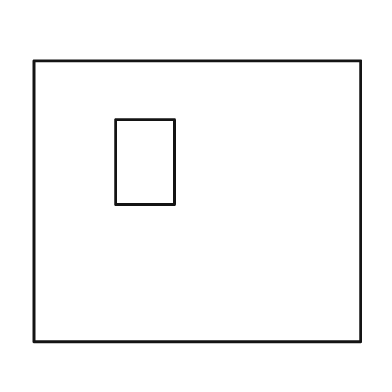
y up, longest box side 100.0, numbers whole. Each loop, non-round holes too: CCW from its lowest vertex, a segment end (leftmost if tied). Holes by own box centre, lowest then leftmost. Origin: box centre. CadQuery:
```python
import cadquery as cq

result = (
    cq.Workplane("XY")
    .moveTo(-50.0, -43.0)
    .lineTo(50.0, -43.0)
    .lineTo(50.0, 43.0)
    .lineTo(-50.0, 43.0)
    .close()
    .moveTo(-25.0, -1.0)
    .lineTo(-7.0, -1.0)
    .lineTo(-7.0, 25.0)
    .lineTo(-25.0, 25.0)
    .close()
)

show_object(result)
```